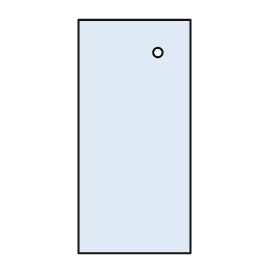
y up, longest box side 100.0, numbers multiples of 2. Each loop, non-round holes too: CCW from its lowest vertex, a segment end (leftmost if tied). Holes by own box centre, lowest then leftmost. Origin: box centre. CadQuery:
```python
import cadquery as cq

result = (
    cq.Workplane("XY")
    .moveTo(-24.0, -50.0)
    .lineTo(24.0, -50.0)
    .lineTo(24.0, 50.0)
    .lineTo(-24.0, 50.0)
    .close()
    .moveTo(10.0, 36.0)
    .circle(2.0)
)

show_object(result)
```